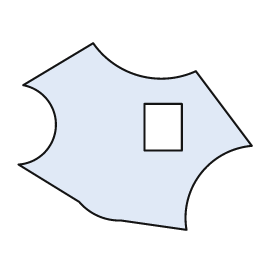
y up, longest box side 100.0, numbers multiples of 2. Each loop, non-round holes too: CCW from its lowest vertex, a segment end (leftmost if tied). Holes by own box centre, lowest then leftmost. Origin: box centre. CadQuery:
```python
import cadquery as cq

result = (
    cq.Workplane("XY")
    .moveTo(22.0, -40.0)
    .threePointArc((28.0, -16.0), (50.0, -4.0))
    .lineTo(26.0, 28.0)
    .threePointArc((2.0, 26.0), (-18.0, 40.0))
    .lineTo(-48.0, 22.0)
    .threePointArc((-34.0, 4.0), (-50.0, -12.0))
    .lineTo(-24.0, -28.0)
    .threePointArc((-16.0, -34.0), (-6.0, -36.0))
    .close()
    .moveTo(4.0, -6.0)
    .lineTo(20.0, -6.0)
    .lineTo(20.0, 14.0)
    .lineTo(4.0, 14.0)
    .close()
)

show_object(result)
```